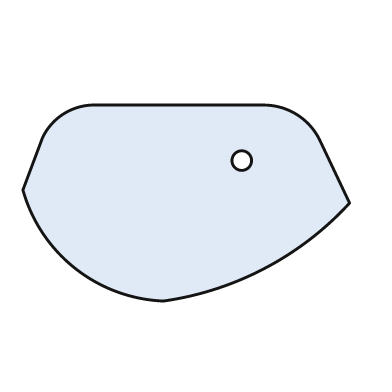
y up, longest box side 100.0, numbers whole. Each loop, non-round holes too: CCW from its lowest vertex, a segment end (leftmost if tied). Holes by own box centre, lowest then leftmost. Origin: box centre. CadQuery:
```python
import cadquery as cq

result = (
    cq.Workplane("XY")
    .moveTo(-7.0, -30.0)
    .threePointArc((24.0, -20.0), (50.0, 0.0))
    .lineTo(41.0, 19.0)
    .threePointArc((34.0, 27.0), (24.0, 30.0))
    .lineTo(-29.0, 30.0)
    .threePointArc((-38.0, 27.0), (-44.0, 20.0))
    .lineTo(-50.0, 4.0)
    .threePointArc((-34.0, -20.0), (-7.0, -30.0))
    .close()
    .moveTo(17.0, 13.0)
    .circle(3.0)
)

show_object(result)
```